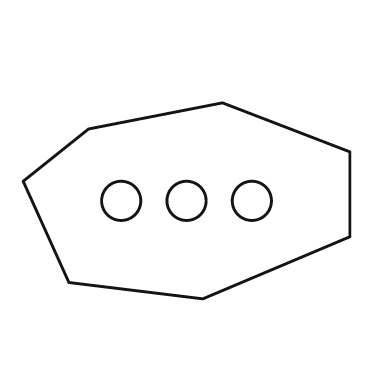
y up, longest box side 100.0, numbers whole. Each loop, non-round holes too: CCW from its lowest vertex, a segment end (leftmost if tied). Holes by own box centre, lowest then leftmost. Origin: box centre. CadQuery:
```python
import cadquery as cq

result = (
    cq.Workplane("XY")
    .moveTo(5.0, -30.0)
    .lineTo(50.0, -11.0)
    .lineTo(50.0, 15.0)
    .lineTo(11.0, 30.0)
    .lineTo(-30.0, 22.0)
    .lineTo(-50.0, 6.0)
    .lineTo(-36.0, -25.0)
    .close()
    .moveTo(-20.0, 0.0)
    .circle(6.0)
    .moveTo(0.0, 0.0)
    .circle(6.0)
    .moveTo(20.0, 0.0)
    .circle(6.0)
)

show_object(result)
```